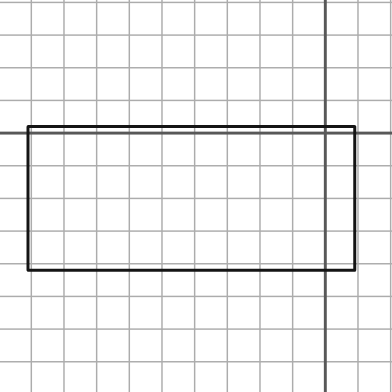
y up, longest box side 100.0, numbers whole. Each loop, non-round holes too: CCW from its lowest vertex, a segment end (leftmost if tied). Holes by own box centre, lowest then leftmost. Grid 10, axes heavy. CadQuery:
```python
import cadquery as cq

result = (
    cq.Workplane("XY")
    .moveTo(-91.0, -42.0)
    .lineTo(9.0, -42.0)
    .lineTo(9.0, 2.0)
    .lineTo(-91.0, 2.0)
    .close()
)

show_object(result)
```